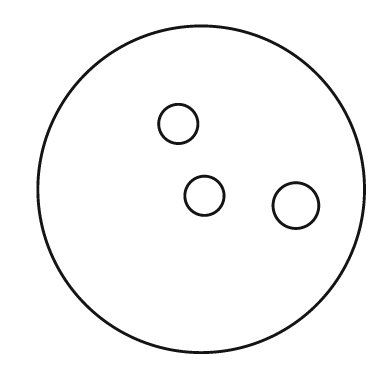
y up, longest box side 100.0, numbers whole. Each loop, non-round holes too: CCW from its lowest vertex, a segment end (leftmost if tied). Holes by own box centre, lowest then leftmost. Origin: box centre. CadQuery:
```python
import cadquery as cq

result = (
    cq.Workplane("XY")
    .moveTo(0.0, 0.0)
    .circle(50.0)
    .moveTo(29.0, -5.0)
    .circle(7.0)
    .moveTo(1.0, -2.0)
    .circle(6.0)
    .moveTo(-7.0, 20.0)
    .circle(6.0)
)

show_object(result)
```